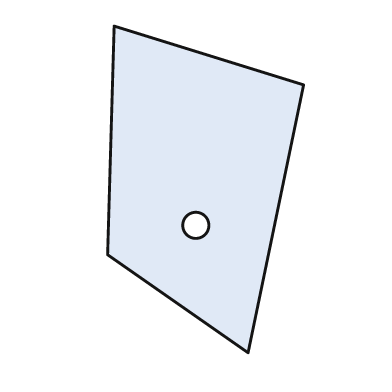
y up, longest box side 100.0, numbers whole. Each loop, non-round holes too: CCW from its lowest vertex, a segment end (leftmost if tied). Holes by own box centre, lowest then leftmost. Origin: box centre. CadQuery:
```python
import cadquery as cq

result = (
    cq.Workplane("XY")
    .moveTo(13.0, -50.0)
    .lineTo(30.0, 32.0)
    .lineTo(-28.0, 50.0)
    .lineTo(-30.0, -20.0)
    .close()
    .moveTo(-3.0, -11.0)
    .circle(4.0)
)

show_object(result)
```